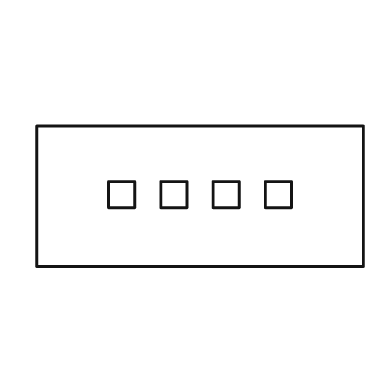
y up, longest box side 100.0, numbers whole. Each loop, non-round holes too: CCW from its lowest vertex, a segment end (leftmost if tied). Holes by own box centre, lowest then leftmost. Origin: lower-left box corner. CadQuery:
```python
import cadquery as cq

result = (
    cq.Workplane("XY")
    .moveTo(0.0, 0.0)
    .lineTo(100.0, 0.0)
    .lineTo(100.0, 43.0)
    .lineTo(0.0, 43.0)
    .close()
    .moveTo(22.0, 18.0)
    .lineTo(30.0, 18.0)
    .lineTo(30.0, 26.0)
    .lineTo(22.0, 26.0)
    .close()
    .moveTo(38.0, 18.0)
    .lineTo(46.0, 18.0)
    .lineTo(46.0, 26.0)
    .lineTo(38.0, 26.0)
    .close()
    .moveTo(54.0, 18.0)
    .lineTo(62.0, 18.0)
    .lineTo(62.0, 26.0)
    .lineTo(54.0, 26.0)
    .close()
    .moveTo(70.0, 18.0)
    .lineTo(78.0, 18.0)
    .lineTo(78.0, 26.0)
    .lineTo(70.0, 26.0)
    .close()
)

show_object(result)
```